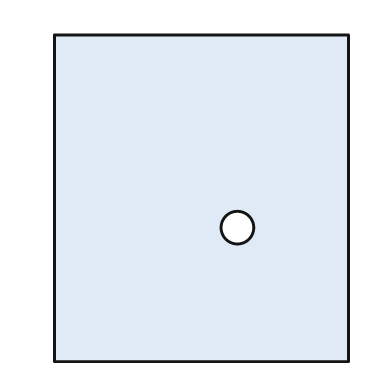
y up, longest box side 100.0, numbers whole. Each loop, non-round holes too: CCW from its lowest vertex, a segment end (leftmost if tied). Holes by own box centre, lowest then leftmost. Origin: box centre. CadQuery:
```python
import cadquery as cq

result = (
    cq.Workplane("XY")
    .moveTo(-45.0, -50.0)
    .lineTo(45.0, -50.0)
    .lineTo(45.0, 50.0)
    .lineTo(-45.0, 50.0)
    .close()
    .moveTo(11.0, -9.0)
    .circle(5.0)
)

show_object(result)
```